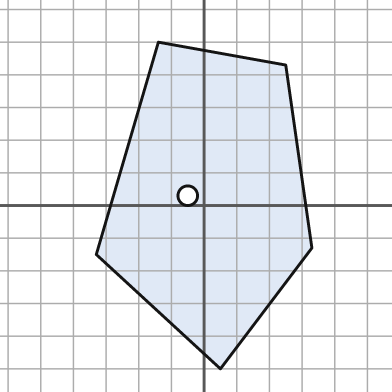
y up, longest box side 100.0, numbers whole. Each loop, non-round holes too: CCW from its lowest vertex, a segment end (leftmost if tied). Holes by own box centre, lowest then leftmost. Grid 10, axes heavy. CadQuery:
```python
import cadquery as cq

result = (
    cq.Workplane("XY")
    .moveTo(5.0, -50.0)
    .lineTo(33.0, -13.0)
    .lineTo(25.0, 43.0)
    .lineTo(-14.0, 50.0)
    .lineTo(-33.0, -15.0)
    .close()
    .moveTo(-5.0, 3.0)
    .circle(3.0)
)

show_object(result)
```